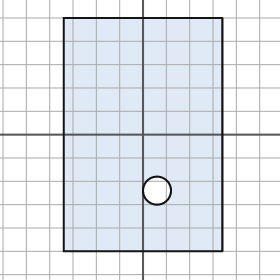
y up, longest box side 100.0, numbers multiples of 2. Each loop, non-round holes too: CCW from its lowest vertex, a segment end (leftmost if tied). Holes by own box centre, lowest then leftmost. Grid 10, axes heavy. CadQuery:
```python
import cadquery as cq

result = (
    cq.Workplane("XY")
    .moveTo(-34.0, -50.0)
    .lineTo(34.0, -50.0)
    .lineTo(34.0, 50.0)
    .lineTo(-34.0, 50.0)
    .close()
    .moveTo(6.0, -24.0)
    .circle(6.0)
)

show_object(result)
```